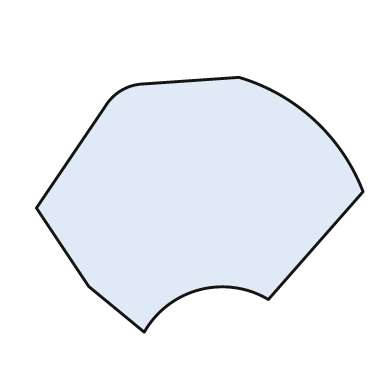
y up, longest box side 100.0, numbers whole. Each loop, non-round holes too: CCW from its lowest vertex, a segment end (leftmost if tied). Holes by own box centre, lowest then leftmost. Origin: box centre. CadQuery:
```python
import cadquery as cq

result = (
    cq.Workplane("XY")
    .moveTo(-17.0, -39.0)
    .threePointArc((0.0, -26.0), (21.0, -29.0))
    .lineTo(50.0, 4.0)
    .threePointArc((35.0, 26.0), (12.0, 39.0))
    .lineTo(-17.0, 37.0)
    .threePointArc((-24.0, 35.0), (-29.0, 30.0))
    .lineTo(-50.0, -1.0)
    .lineTo(-34.0, -25.0)
    .close()
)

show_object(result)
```